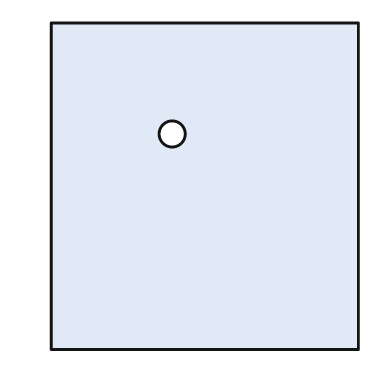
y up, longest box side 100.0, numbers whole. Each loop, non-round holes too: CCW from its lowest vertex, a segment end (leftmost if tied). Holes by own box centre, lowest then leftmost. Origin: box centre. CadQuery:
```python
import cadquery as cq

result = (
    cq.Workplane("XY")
    .moveTo(-47.0, -50.0)
    .lineTo(47.0, -50.0)
    .lineTo(47.0, 50.0)
    .lineTo(-47.0, 50.0)
    .close()
    .moveTo(-10.0, 16.0)
    .circle(4.0)
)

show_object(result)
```